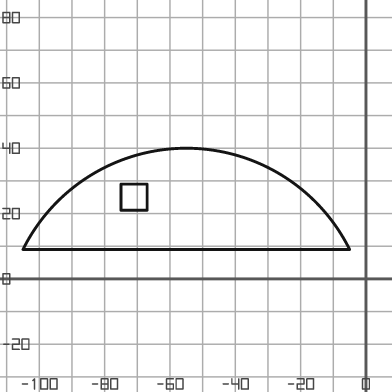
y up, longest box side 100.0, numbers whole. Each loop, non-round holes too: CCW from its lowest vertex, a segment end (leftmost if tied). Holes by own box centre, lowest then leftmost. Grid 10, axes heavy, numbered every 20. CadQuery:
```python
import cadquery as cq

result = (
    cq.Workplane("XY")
    .moveTo(-105.0, 9.0)
    .lineTo(-5.0, 9.0)
    .threePointArc((-55.0, 40.0), (-105.0, 9.0))
    .close()
    .moveTo(-75.0, 21.0)
    .lineTo(-67.0, 21.0)
    .lineTo(-67.0, 29.0)
    .lineTo(-75.0, 29.0)
    .close()
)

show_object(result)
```